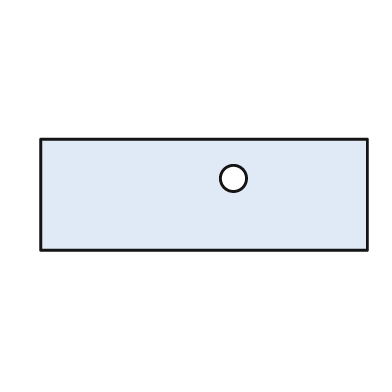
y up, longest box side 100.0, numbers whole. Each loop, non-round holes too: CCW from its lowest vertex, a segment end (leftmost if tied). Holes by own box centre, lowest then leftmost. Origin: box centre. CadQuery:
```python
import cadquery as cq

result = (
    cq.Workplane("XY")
    .moveTo(-50.0, -17.0)
    .lineTo(50.0, -17.0)
    .lineTo(50.0, 17.0)
    .lineTo(-50.0, 17.0)
    .close()
    .moveTo(9.0, 5.0)
    .circle(4.0)
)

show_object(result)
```